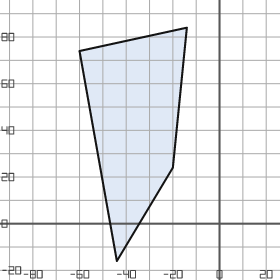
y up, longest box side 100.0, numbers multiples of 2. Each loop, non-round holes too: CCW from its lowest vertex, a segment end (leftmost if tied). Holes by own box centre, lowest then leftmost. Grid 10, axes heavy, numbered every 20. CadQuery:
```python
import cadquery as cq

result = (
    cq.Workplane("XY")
    .moveTo(-44.0, -16.0)
    .lineTo(-20.0, 24.0)
    .lineTo(-14.0, 84.0)
    .lineTo(-60.0, 74.0)
    .close()
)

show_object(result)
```